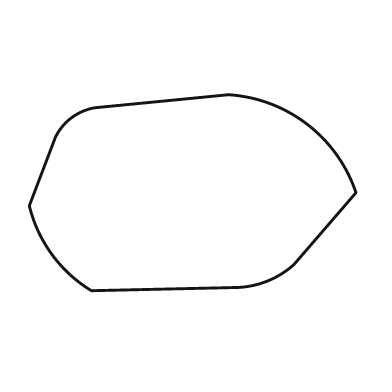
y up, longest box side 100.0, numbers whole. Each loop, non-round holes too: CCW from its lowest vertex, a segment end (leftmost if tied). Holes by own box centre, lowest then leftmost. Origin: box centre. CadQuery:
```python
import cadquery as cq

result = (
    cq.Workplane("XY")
    .moveTo(-31.0, -30.0)
    .lineTo(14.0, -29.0)
    .threePointArc((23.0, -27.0), (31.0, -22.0))
    .lineTo(50.0, 0.0)
    .threePointArc((35.0, 21.0), (11.0, 30.0))
    .lineTo(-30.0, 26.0)
    .threePointArc((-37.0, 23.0), (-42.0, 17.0))
    .lineTo(-50.0, -4.0)
    .threePointArc((-43.0, -19.0), (-31.0, -30.0))
    .close()
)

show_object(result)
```